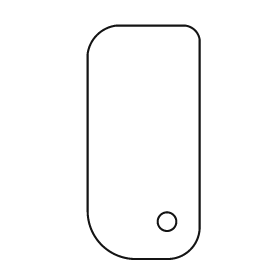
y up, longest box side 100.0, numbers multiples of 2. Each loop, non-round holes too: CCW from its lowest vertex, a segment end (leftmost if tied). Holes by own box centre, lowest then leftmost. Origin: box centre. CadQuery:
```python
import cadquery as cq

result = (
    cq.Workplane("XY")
    .moveTo(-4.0, -50.0)
    .lineTo(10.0, -50.0)
    .threePointArc((20.0, -46.0), (24.0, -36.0))
    .lineTo(24.0, 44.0)
    .threePointArc((22.0, 48.0), (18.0, 50.0))
    .lineTo(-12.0, 50.0)
    .threePointArc((-20.0, 46.0), (-24.0, 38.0))
    .lineTo(-24.0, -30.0)
    .threePointArc((-18.0, -44.0), (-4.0, -50.0))
    .close()
    .moveTo(10.0, -34.0)
    .circle(4.0)
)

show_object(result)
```